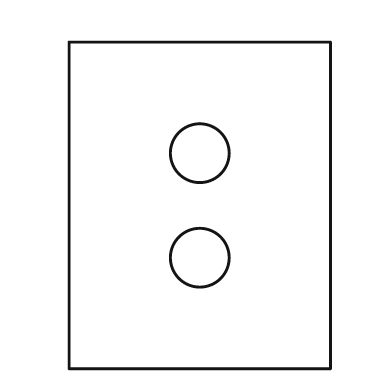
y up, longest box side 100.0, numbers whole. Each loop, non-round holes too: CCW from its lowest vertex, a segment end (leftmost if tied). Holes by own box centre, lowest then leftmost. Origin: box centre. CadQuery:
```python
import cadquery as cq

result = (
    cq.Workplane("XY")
    .moveTo(-40.0, -50.0)
    .lineTo(40.0, -50.0)
    .lineTo(40.0, 50.0)
    .lineTo(-40.0, 50.0)
    .close()
    .moveTo(0.0, -16.0)
    .circle(9.0)
    .moveTo(0.0, 16.0)
    .circle(9.0)
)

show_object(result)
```